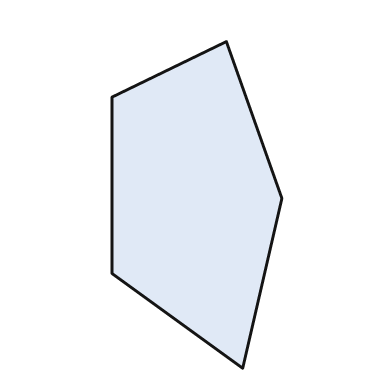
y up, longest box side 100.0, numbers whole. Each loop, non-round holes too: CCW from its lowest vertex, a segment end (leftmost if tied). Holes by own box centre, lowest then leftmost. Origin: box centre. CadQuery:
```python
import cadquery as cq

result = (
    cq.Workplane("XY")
    .moveTo(14.0, -50.0)
    .lineTo(26.0, 2.0)
    .lineTo(9.0, 50.0)
    .lineTo(-26.0, 33.0)
    .lineTo(-26.0, -21.0)
    .close()
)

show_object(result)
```